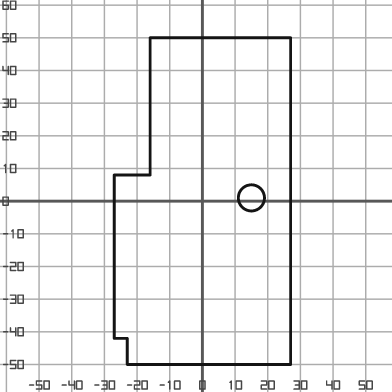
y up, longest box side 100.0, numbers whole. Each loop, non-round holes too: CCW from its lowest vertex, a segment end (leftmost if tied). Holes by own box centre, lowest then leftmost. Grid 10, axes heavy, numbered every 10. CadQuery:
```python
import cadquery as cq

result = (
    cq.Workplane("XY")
    .moveTo(-23.0, -50.0)
    .lineTo(27.0, -50.0)
    .lineTo(27.0, 50.0)
    .lineTo(-16.0, 50.0)
    .lineTo(-16.0, 8.0)
    .lineTo(-27.0, 8.0)
    .lineTo(-27.0, -42.0)
    .lineTo(-23.0, -42.0)
    .close()
    .moveTo(15.0, 1.0)
    .circle(4.0)
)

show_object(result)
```